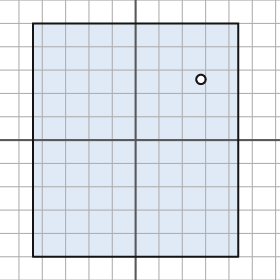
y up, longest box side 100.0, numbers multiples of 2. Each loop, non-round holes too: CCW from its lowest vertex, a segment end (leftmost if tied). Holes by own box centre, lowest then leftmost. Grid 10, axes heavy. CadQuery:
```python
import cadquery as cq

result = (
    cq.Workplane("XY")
    .moveTo(-44.0, -50.0)
    .lineTo(44.0, -50.0)
    .lineTo(44.0, 50.0)
    .lineTo(-44.0, 50.0)
    .close()
    .moveTo(28.0, 26.0)
    .circle(2.0)
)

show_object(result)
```